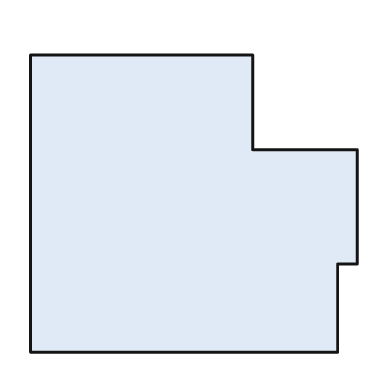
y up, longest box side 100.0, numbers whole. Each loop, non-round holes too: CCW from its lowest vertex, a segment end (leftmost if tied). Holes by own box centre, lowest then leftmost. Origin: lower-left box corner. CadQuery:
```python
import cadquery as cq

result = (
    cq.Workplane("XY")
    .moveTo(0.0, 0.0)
    .lineTo(94.0, 0.0)
    .lineTo(94.0, 27.0)
    .lineTo(100.0, 27.0)
    .lineTo(100.0, 62.0)
    .lineTo(68.0, 62.0)
    .lineTo(68.0, 91.0)
    .lineTo(0.0, 91.0)
    .close()
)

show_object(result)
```